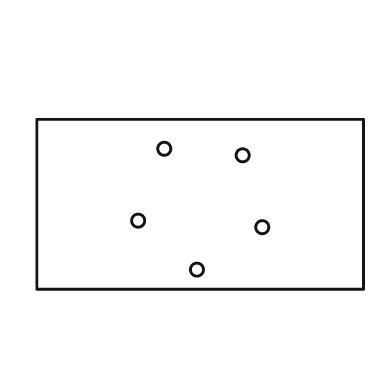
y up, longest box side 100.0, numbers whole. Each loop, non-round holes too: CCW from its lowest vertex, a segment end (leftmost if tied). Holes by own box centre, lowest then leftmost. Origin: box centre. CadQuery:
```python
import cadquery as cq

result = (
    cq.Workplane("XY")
    .moveTo(-50.0, -26.0)
    .lineTo(50.0, -26.0)
    .lineTo(50.0, 26.0)
    .lineTo(-50.0, 26.0)
    .close()
    .moveTo(-1.0, -20.0)
    .circle(2.0)
    .moveTo(19.0, -7.0)
    .circle(2.0)
    .moveTo(-19.0, -5.0)
    .circle(2.0)
    .moveTo(13.0, 15.0)
    .circle(2.0)
    .moveTo(-11.0, 17.0)
    .circle(2.0)
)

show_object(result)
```